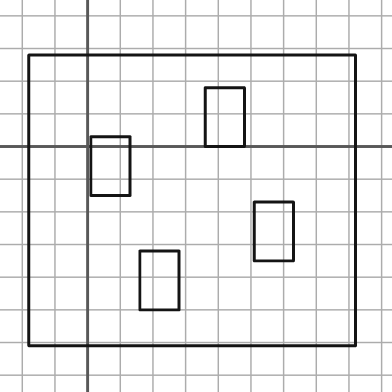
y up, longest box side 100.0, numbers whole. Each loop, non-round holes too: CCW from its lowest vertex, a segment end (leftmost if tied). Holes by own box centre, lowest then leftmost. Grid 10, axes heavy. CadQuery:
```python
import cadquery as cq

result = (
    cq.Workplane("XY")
    .moveTo(-18.0, -61.0)
    .lineTo(82.0, -61.0)
    .lineTo(82.0, 28.0)
    .lineTo(-18.0, 28.0)
    .close()
    .moveTo(16.0, -50.0)
    .lineTo(28.0, -50.0)
    .lineTo(28.0, -32.0)
    .lineTo(16.0, -32.0)
    .close()
    .moveTo(51.0, -35.0)
    .lineTo(63.0, -35.0)
    .lineTo(63.0, -17.0)
    .lineTo(51.0, -17.0)
    .close()
    .moveTo(1.0, -15.0)
    .lineTo(13.0, -15.0)
    .lineTo(13.0, 3.0)
    .lineTo(1.0, 3.0)
    .close()
    .moveTo(36.0, 0.0)
    .lineTo(48.0, 0.0)
    .lineTo(48.0, 18.0)
    .lineTo(36.0, 18.0)
    .close()
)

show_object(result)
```